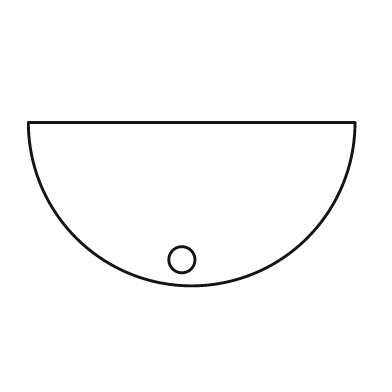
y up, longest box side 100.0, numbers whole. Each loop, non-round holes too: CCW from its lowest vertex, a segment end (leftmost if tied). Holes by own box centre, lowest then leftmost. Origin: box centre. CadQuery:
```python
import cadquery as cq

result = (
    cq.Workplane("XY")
    .moveTo(-50.0, 25.0)
    .threePointArc((0.0, -25.0), (50.0, 25.0))
    .close()
    .moveTo(-3.0, -17.0)
    .circle(4.0)
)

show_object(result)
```